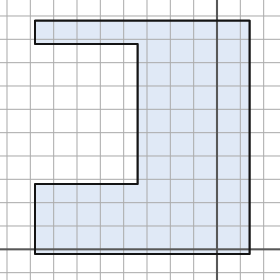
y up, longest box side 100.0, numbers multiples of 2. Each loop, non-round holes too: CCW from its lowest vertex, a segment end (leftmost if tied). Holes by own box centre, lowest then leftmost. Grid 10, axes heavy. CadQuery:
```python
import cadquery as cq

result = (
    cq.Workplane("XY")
    .moveTo(-78.0, -2.0)
    .lineTo(14.0, -2.0)
    .lineTo(14.0, 98.0)
    .lineTo(-78.0, 98.0)
    .lineTo(-78.0, 88.0)
    .lineTo(-34.0, 88.0)
    .lineTo(-34.0, 28.0)
    .lineTo(-78.0, 28.0)
    .close()
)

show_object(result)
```